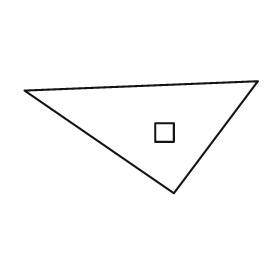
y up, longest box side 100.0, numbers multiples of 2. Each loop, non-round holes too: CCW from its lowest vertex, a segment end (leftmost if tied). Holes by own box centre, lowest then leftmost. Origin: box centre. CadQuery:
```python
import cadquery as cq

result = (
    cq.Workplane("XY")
    .moveTo(14.0, -24.0)
    .lineTo(50.0, 24.0)
    .lineTo(-50.0, 20.0)
    .close()
    .moveTo(6.0, -2.0)
    .lineTo(14.0, -2.0)
    .lineTo(14.0, 6.0)
    .lineTo(6.0, 6.0)
    .close()
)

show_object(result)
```